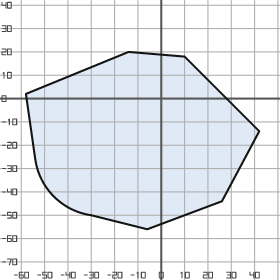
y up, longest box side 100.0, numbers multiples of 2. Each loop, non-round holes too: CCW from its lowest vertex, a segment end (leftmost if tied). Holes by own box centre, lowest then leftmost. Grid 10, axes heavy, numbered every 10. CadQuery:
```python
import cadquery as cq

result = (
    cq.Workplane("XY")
    .moveTo(-6.0, -56.0)
    .lineTo(26.0, -44.0)
    .lineTo(42.0, -14.0)
    .lineTo(10.0, 18.0)
    .lineTo(-14.0, 20.0)
    .lineTo(-58.0, 2.0)
    .lineTo(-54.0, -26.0)
    .threePointArc((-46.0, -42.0), (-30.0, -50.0))
    .close()
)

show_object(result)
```